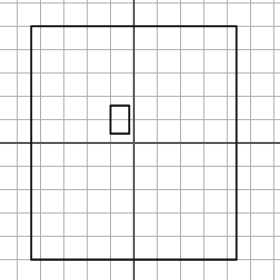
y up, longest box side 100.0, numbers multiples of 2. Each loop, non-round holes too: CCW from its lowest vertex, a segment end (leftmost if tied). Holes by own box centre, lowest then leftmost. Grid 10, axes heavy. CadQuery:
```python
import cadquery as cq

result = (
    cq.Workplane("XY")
    .moveTo(-44.0, -50.0)
    .lineTo(44.0, -50.0)
    .lineTo(44.0, 50.0)
    .lineTo(-44.0, 50.0)
    .close()
    .moveTo(-10.0, 4.0)
    .lineTo(-2.0, 4.0)
    .lineTo(-2.0, 16.0)
    .lineTo(-10.0, 16.0)
    .close()
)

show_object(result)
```